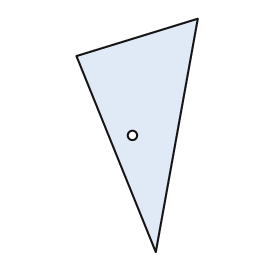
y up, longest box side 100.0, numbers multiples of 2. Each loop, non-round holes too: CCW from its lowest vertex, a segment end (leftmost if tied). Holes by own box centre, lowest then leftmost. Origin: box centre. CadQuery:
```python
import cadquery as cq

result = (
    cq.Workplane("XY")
    .moveTo(8.0, -50.0)
    .lineTo(26.0, 50.0)
    .lineTo(-26.0, 34.0)
    .close()
    .moveTo(-2.0, 0.0)
    .circle(2.0)
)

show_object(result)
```